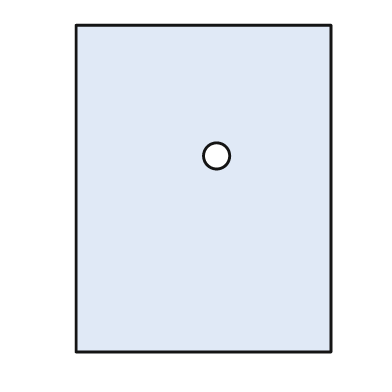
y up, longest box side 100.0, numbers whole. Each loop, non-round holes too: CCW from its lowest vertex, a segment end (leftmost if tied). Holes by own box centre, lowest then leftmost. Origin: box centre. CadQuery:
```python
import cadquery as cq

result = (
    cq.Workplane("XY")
    .moveTo(-39.0, -50.0)
    .lineTo(39.0, -50.0)
    .lineTo(39.0, 50.0)
    .lineTo(-39.0, 50.0)
    .close()
    .moveTo(4.0, 10.0)
    .circle(4.0)
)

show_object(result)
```